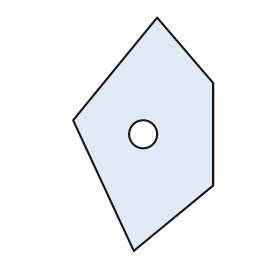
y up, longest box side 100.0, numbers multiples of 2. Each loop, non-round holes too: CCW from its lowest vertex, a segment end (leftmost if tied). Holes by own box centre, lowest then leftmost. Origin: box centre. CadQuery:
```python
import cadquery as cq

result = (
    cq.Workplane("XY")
    .moveTo(-4.0, -50.0)
    .lineTo(30.0, -22.0)
    .lineTo(30.0, 22.0)
    .lineTo(6.0, 50.0)
    .lineTo(-30.0, 6.0)
    .close()
    .moveTo(0.0, 0.0)
    .circle(6.0)
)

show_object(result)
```